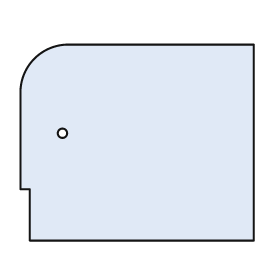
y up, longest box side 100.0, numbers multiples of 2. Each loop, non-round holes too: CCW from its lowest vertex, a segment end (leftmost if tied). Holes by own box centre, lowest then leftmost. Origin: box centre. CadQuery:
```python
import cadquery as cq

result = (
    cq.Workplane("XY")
    .moveTo(-46.0, -42.0)
    .lineTo(50.0, -42.0)
    .lineTo(50.0, 42.0)
    .lineTo(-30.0, 42.0)
    .threePointArc((-44.0, 36.0), (-50.0, 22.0))
    .lineTo(-50.0, -20.0)
    .lineTo(-46.0, -20.0)
    .close()
    .moveTo(-32.0, 4.0)
    .circle(2.0)
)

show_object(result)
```